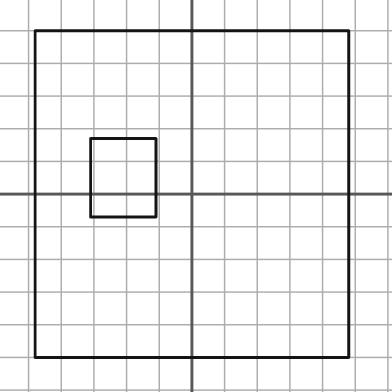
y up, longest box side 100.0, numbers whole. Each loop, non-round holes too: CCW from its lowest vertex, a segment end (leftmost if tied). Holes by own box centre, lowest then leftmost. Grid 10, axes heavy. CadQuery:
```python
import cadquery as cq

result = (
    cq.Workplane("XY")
    .moveTo(-48.0, -50.0)
    .lineTo(48.0, -50.0)
    .lineTo(48.0, 50.0)
    .lineTo(-48.0, 50.0)
    .close()
    .moveTo(-31.0, -7.0)
    .lineTo(-11.0, -7.0)
    .lineTo(-11.0, 17.0)
    .lineTo(-31.0, 17.0)
    .close()
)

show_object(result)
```